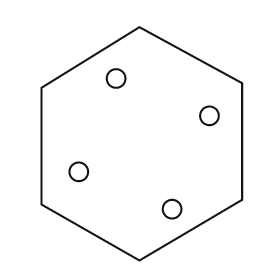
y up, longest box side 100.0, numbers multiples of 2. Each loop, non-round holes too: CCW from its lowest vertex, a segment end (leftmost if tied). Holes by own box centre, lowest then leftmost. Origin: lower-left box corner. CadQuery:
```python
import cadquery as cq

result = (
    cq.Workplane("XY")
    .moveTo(42.0, 0.0)
    .lineTo(86.0, 26.0)
    .lineTo(86.0, 76.0)
    .lineTo(42.0, 100.0)
    .lineTo(0.0, 74.0)
    .lineTo(0.0, 24.0)
    .close()
    .moveTo(56.0, 22.0)
    .circle(4.0)
    .moveTo(16.0, 38.0)
    .circle(4.0)
    .moveTo(72.0, 62.0)
    .circle(4.0)
    .moveTo(32.0, 78.0)
    .circle(4.0)
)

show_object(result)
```